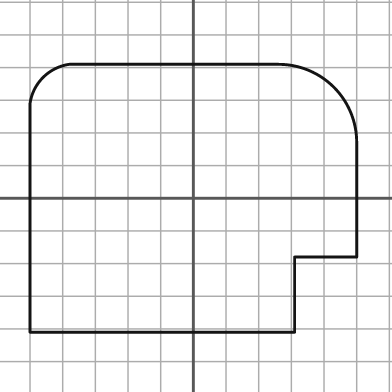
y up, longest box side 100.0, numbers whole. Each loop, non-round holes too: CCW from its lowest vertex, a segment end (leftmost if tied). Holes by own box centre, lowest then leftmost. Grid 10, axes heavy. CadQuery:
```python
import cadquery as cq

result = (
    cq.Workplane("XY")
    .moveTo(-50.0, -41.0)
    .lineTo(31.0, -41.0)
    .lineTo(31.0, -18.0)
    .lineTo(50.0, -18.0)
    .lineTo(50.0, 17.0)
    .threePointArc((43.0, 34.0), (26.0, 41.0))
    .lineTo(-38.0, 41.0)
    .threePointArc((-46.0, 37.0), (-50.0, 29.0))
    .close()
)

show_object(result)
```